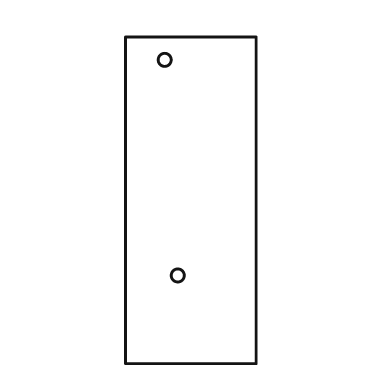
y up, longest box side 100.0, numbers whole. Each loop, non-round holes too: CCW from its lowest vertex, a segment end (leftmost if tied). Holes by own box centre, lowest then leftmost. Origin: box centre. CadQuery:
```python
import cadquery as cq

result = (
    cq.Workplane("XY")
    .moveTo(-20.0, -50.0)
    .lineTo(20.0, -50.0)
    .lineTo(20.0, 50.0)
    .lineTo(-20.0, 50.0)
    .close()
    .moveTo(-4.0, -23.0)
    .circle(2.0)
    .moveTo(-8.0, 43.0)
    .circle(2.0)
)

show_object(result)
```